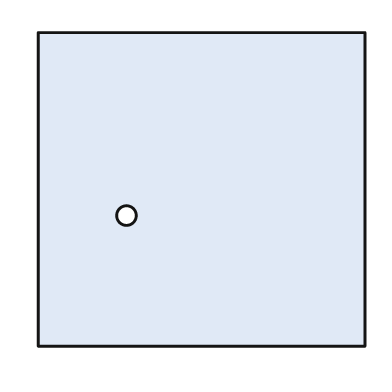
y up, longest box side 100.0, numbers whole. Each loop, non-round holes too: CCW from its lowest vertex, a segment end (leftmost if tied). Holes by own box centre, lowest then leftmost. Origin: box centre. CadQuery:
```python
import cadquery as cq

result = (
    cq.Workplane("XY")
    .moveTo(-50.0, -48.0)
    .lineTo(50.0, -48.0)
    .lineTo(50.0, 48.0)
    .lineTo(-50.0, 48.0)
    .close()
    .moveTo(-23.0, -8.0)
    .circle(3.0)
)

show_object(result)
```